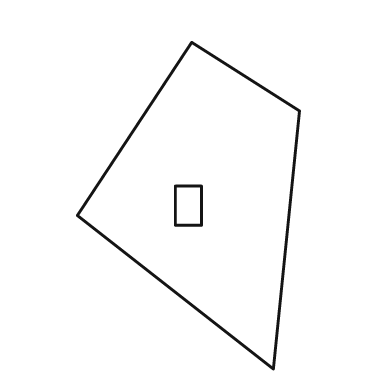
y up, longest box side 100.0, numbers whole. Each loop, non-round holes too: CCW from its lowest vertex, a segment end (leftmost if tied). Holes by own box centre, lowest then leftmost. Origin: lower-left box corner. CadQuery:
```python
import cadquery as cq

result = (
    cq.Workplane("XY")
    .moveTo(60.0, 0.0)
    .lineTo(68.0, 79.0)
    .lineTo(35.0, 100.0)
    .lineTo(0.0, 47.0)
    .close()
    .moveTo(30.0, 44.0)
    .lineTo(38.0, 44.0)
    .lineTo(38.0, 56.0)
    .lineTo(30.0, 56.0)
    .close()
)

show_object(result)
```